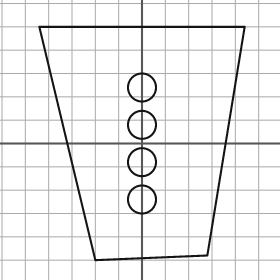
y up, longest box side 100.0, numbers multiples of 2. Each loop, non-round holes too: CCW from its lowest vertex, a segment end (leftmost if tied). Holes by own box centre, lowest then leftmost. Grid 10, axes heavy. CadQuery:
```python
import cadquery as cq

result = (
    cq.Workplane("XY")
    .moveTo(-20.0, -50.0)
    .lineTo(28.0, -48.0)
    .lineTo(44.0, 50.0)
    .lineTo(-44.0, 50.0)
    .close()
    .moveTo(0.0, -24.0)
    .circle(6.0)
    .moveTo(0.0, -8.0)
    .circle(6.0)
    .moveTo(0.0, 8.0)
    .circle(6.0)
    .moveTo(0.0, 24.0)
    .circle(6.0)
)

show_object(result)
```